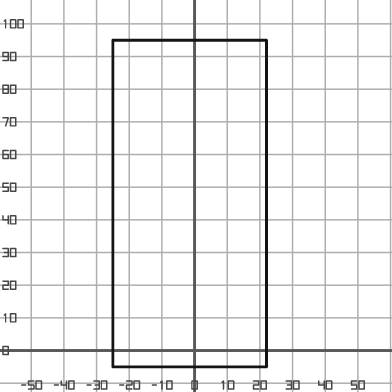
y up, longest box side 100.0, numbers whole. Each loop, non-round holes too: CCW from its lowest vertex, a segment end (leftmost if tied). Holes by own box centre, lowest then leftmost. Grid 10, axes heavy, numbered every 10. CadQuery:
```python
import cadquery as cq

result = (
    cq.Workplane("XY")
    .moveTo(-25.0, -5.0)
    .lineTo(22.0, -5.0)
    .lineTo(22.0, 95.0)
    .lineTo(-25.0, 95.0)
    .close()
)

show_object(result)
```